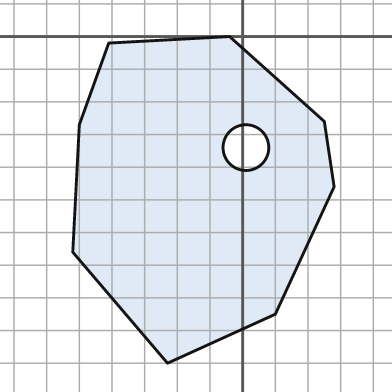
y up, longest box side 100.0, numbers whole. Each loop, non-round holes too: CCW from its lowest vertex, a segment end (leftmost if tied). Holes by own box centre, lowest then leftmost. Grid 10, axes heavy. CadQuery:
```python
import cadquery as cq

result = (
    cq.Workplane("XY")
    .moveTo(-23.0, -100.0)
    .lineTo(10.0, -85.0)
    .lineTo(28.0, -46.0)
    .lineTo(25.0, -26.0)
    .lineTo(-4.0, 0.0)
    .lineTo(-41.0, -2.0)
    .lineTo(-50.0, -27.0)
    .lineTo(-52.0, -66.0)
    .close()
    .moveTo(1.0, -34.0)
    .circle(7.0)
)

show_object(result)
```